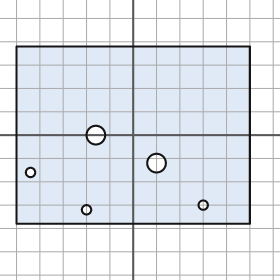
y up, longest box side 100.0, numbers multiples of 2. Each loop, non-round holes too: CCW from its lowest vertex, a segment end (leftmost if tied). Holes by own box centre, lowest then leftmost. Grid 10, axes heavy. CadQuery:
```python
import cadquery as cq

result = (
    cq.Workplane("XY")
    .moveTo(-50.0, -38.0)
    .lineTo(50.0, -38.0)
    .lineTo(50.0, 38.0)
    .lineTo(-50.0, 38.0)
    .close()
    .moveTo(-20.0, -32.0)
    .circle(2.0)
    .moveTo(30.0, -30.0)
    .circle(2.0)
    .moveTo(-44.0, -16.0)
    .circle(2.0)
    .moveTo(10.0, -12.0)
    .circle(4.0)
    .moveTo(-16.0, 0.0)
    .circle(4.0)
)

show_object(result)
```